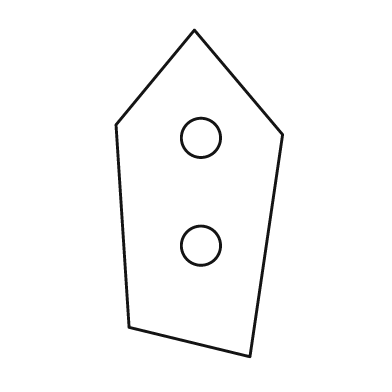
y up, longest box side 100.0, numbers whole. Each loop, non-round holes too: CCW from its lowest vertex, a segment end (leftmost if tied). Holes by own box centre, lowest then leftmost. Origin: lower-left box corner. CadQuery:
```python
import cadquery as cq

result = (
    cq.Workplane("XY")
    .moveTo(41.0, 0.0)
    .lineTo(51.0, 68.0)
    .lineTo(24.0, 100.0)
    .lineTo(0.0, 71.0)
    .lineTo(4.0, 9.0)
    .close()
    .moveTo(26.0, 34.0)
    .circle(6.0)
    .moveTo(26.0, 67.0)
    .circle(6.0)
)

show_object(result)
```